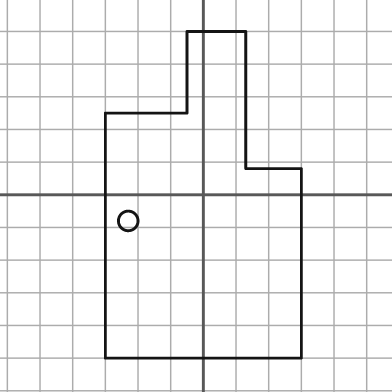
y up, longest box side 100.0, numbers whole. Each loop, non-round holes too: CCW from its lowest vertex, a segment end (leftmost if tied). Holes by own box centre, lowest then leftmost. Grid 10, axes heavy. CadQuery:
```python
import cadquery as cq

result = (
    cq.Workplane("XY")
    .moveTo(-30.0, -50.0)
    .lineTo(30.0, -50.0)
    .lineTo(30.0, 8.0)
    .lineTo(13.0, 8.0)
    .lineTo(13.0, 50.0)
    .lineTo(-5.0, 50.0)
    .lineTo(-5.0, 25.0)
    .lineTo(-30.0, 25.0)
    .close()
    .moveTo(-23.0, -8.0)
    .circle(3.0)
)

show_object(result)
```